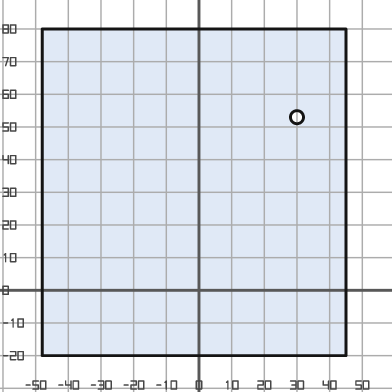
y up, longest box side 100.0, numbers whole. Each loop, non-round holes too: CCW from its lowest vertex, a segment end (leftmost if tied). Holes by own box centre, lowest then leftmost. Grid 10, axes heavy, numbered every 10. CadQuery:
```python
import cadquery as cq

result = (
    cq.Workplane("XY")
    .moveTo(-48.0, -20.0)
    .lineTo(45.0, -20.0)
    .lineTo(45.0, 80.0)
    .lineTo(-48.0, 80.0)
    .close()
    .moveTo(30.0, 53.0)
    .circle(2.0)
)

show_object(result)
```